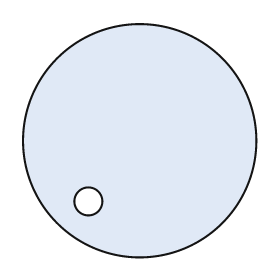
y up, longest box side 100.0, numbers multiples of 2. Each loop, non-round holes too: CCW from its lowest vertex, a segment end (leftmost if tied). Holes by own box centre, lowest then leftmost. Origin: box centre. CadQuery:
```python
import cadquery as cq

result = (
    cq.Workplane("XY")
    .moveTo(0.0, 0.0)
    .circle(50.0)
    .moveTo(-22.0, -26.0)
    .circle(6.0)
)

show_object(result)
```